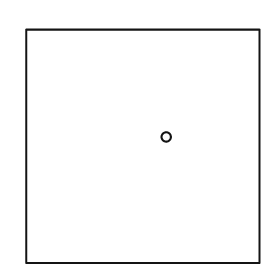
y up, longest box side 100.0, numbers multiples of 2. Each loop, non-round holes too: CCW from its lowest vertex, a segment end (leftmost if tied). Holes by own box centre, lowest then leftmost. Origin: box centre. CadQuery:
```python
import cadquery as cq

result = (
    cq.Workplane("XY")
    .moveTo(-50.0, -50.0)
    .lineTo(50.0, -50.0)
    .lineTo(50.0, 50.0)
    .lineTo(-50.0, 50.0)
    .close()
    .moveTo(10.0, 4.0)
    .circle(2.0)
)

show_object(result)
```